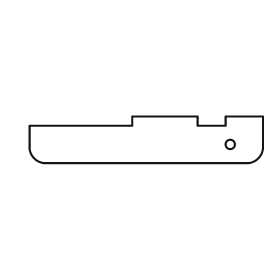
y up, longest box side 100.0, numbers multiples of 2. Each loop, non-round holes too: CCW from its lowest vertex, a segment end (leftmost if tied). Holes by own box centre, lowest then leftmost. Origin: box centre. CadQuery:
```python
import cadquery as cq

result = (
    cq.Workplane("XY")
    .moveTo(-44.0, -10.0)
    .lineTo(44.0, -10.0)
    .threePointArc((48.0, -8.0), (50.0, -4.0))
    .lineTo(50.0, 10.0)
    .lineTo(34.0, 10.0)
    .lineTo(34.0, 6.0)
    .lineTo(22.0, 6.0)
    .lineTo(22.0, 10.0)
    .lineTo(-6.0, 10.0)
    .lineTo(-6.0, 6.0)
    .lineTo(-50.0, 6.0)
    .lineTo(-50.0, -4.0)
    .threePointArc((-48.0, -8.0), (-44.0, -10.0))
    .close()
    .moveTo(36.0, -2.0)
    .circle(2.0)
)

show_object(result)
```